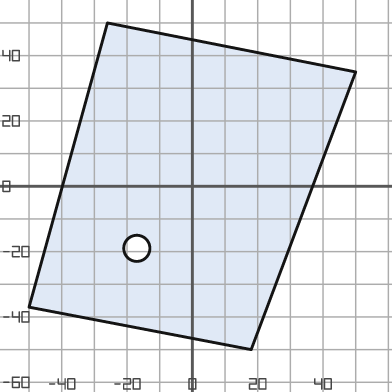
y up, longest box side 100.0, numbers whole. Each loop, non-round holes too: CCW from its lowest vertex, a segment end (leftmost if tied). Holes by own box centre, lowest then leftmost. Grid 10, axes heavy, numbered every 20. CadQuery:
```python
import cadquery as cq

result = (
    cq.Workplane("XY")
    .moveTo(18.0, -50.0)
    .lineTo(50.0, 35.0)
    .lineTo(-26.0, 50.0)
    .lineTo(-50.0, -37.0)
    .close()
    .moveTo(-17.0, -19.0)
    .circle(4.0)
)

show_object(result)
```